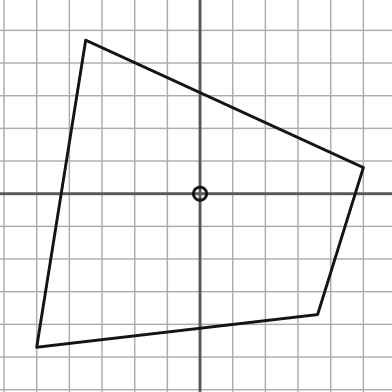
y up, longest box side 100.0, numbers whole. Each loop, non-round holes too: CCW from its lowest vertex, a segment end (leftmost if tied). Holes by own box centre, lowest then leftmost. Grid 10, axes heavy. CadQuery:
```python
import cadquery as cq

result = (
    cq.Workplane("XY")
    .moveTo(-50.0, -47.0)
    .lineTo(36.0, -37.0)
    .lineTo(50.0, 8.0)
    .lineTo(-35.0, 47.0)
    .close()
    .moveTo(0.0, 0.0)
    .circle(2.0)
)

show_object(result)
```